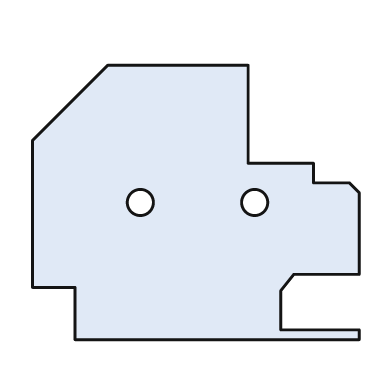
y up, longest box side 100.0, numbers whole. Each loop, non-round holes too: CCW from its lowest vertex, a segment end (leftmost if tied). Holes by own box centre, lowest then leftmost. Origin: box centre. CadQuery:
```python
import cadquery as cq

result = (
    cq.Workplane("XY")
    .moveTo(-37.0, -42.0)
    .lineTo(50.0, -42.0)
    .lineTo(50.0, -39.0)
    .lineTo(26.0, -39.0)
    .lineTo(26.0, -27.0)
    .lineTo(30.0, -22.0)
    .lineTo(50.0, -22.0)
    .lineTo(50.0, 3.0)
    .lineTo(47.0, 6.0)
    .lineTo(36.0, 6.0)
    .lineTo(36.0, 12.0)
    .lineTo(16.0, 12.0)
    .lineTo(16.0, 42.0)
    .lineTo(-27.0, 42.0)
    .lineTo(-50.0, 19.0)
    .lineTo(-50.0, -26.0)
    .lineTo(-37.0, -26.0)
    .close()
    .moveTo(-17.0, 0.0)
    .circle(4.0)
    .moveTo(18.0, 0.0)
    .circle(4.0)
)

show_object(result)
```